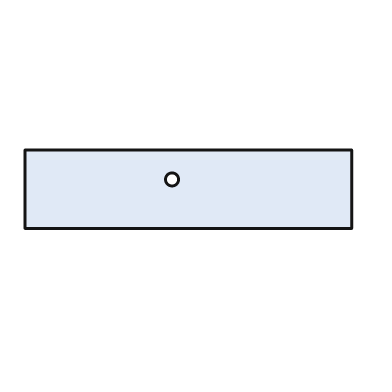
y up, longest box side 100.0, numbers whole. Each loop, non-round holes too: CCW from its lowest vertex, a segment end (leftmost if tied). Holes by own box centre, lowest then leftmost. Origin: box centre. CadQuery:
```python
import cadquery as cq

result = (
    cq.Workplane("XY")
    .moveTo(-50.0, -12.0)
    .lineTo(50.0, -12.0)
    .lineTo(50.0, 12.0)
    .lineTo(-50.0, 12.0)
    .close()
    .moveTo(-5.0, 3.0)
    .circle(2.0)
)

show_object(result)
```